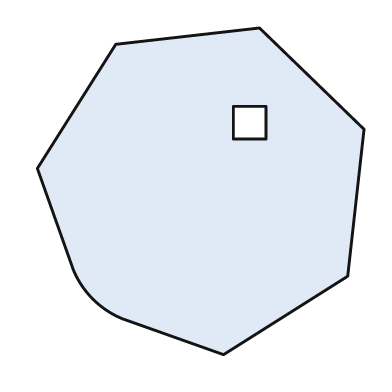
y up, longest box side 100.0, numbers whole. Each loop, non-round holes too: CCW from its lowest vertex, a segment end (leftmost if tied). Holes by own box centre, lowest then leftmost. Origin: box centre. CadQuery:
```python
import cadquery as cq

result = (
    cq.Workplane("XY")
    .moveTo(7.0, -50.0)
    .lineTo(45.0, -26.0)
    .lineTo(50.0, 19.0)
    .lineTo(18.0, 50.0)
    .lineTo(-26.0, 45.0)
    .lineTo(-50.0, 7.0)
    .lineTo(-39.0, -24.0)
    .threePointArc((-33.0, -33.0), (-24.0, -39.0))
    .close()
    .moveTo(10.0, 16.0)
    .lineTo(20.0, 16.0)
    .lineTo(20.0, 26.0)
    .lineTo(10.0, 26.0)
    .close()
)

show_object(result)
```